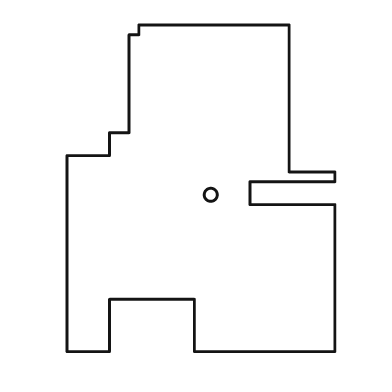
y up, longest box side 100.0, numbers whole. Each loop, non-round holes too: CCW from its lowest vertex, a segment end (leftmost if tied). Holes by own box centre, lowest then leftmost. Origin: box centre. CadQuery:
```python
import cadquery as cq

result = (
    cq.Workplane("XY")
    .moveTo(-41.0, -50.0)
    .lineTo(-28.0, -50.0)
    .lineTo(-28.0, -34.0)
    .lineTo(-2.0, -34.0)
    .lineTo(-2.0, -50.0)
    .lineTo(41.0, -50.0)
    .lineTo(41.0, -5.0)
    .lineTo(15.0, -5.0)
    .lineTo(15.0, 2.0)
    .lineTo(41.0, 2.0)
    .lineTo(41.0, 5.0)
    .lineTo(27.0, 5.0)
    .lineTo(27.0, 50.0)
    .lineTo(-19.0, 50.0)
    .lineTo(-19.0, 47.0)
    .lineTo(-22.0, 47.0)
    .lineTo(-22.0, 17.0)
    .lineTo(-28.0, 17.0)
    .lineTo(-28.0, 10.0)
    .lineTo(-41.0, 10.0)
    .close()
    .moveTo(3.0, -2.0)
    .circle(2.0)
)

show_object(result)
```